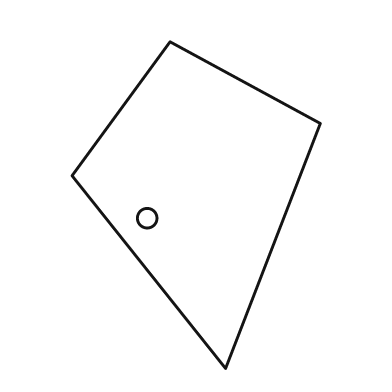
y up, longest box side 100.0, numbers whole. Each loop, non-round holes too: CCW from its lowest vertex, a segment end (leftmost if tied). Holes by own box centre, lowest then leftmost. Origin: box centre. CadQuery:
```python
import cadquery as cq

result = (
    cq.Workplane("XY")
    .moveTo(9.0, -50.0)
    .lineTo(38.0, 25.0)
    .lineTo(-8.0, 50.0)
    .lineTo(-38.0, 9.0)
    .close()
    .moveTo(-15.0, -4.0)
    .circle(3.0)
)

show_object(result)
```